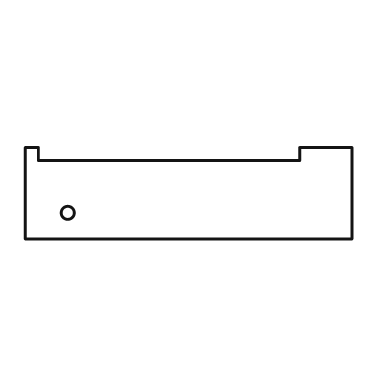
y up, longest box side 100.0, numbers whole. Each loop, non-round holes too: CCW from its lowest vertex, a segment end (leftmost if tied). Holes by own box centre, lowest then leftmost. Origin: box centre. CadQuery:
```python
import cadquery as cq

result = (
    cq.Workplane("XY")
    .moveTo(-50.0, -14.0)
    .lineTo(50.0, -14.0)
    .lineTo(50.0, 14.0)
    .lineTo(34.0, 14.0)
    .lineTo(34.0, 10.0)
    .lineTo(-46.0, 10.0)
    .lineTo(-46.0, 14.0)
    .lineTo(-50.0, 14.0)
    .close()
    .moveTo(-37.0, -6.0)
    .circle(2.0)
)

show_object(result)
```